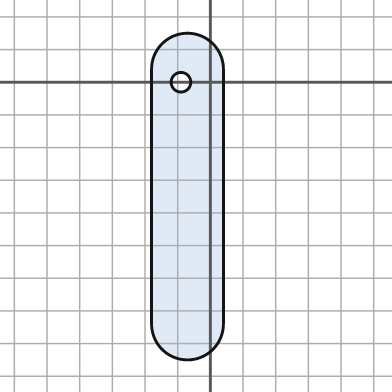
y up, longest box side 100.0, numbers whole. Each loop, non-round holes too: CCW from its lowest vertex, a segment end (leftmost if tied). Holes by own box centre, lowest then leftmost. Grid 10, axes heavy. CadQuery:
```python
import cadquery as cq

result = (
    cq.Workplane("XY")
    .moveTo(-18.0, -74.0)
    .threePointArc((-7.0, -85.0), (4.0, -74.0))
    .lineTo(4.0, 4.0)
    .threePointArc((-7.0, 15.0), (-18.0, 4.0))
    .close()
    .moveTo(-9.0, 0.0)
    .circle(3.0)
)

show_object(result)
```